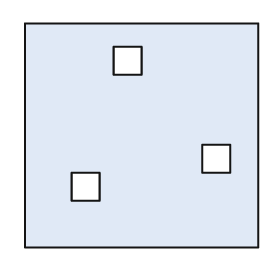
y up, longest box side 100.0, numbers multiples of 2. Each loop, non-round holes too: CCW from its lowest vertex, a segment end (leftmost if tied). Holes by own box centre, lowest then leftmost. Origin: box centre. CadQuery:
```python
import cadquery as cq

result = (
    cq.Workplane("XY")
    .moveTo(-50.0, -48.0)
    .lineTo(50.0, -48.0)
    .lineTo(50.0, 48.0)
    .lineTo(-50.0, 48.0)
    .close()
    .moveTo(-30.0, -28.0)
    .lineTo(-18.0, -28.0)
    .lineTo(-18.0, -16.0)
    .lineTo(-30.0, -16.0)
    .close()
    .moveTo(26.0, -16.0)
    .lineTo(38.0, -16.0)
    .lineTo(38.0, -4.0)
    .lineTo(26.0, -4.0)
    .close()
    .moveTo(-12.0, 26.0)
    .lineTo(0.0, 26.0)
    .lineTo(0.0, 38.0)
    .lineTo(-12.0, 38.0)
    .close()
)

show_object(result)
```